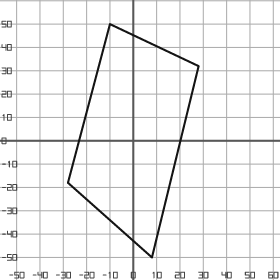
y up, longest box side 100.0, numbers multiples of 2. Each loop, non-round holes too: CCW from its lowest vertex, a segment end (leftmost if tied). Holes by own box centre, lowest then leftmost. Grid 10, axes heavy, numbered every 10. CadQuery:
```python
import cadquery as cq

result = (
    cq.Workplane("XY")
    .moveTo(8.0, -50.0)
    .lineTo(28.0, 32.0)
    .lineTo(-10.0, 50.0)
    .lineTo(-28.0, -18.0)
    .close()
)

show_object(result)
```